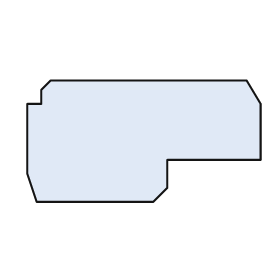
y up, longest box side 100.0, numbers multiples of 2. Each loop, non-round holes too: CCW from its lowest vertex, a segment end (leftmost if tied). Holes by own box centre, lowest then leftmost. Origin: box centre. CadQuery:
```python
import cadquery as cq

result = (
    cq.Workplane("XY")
    .moveTo(-46.0, -26.0)
    .lineTo(4.0, -26.0)
    .lineTo(10.0, -20.0)
    .lineTo(10.0, -8.0)
    .lineTo(50.0, -8.0)
    .lineTo(50.0, 16.0)
    .lineTo(44.0, 26.0)
    .lineTo(-40.0, 26.0)
    .lineTo(-44.0, 22.0)
    .lineTo(-44.0, 16.0)
    .lineTo(-50.0, 16.0)
    .lineTo(-50.0, -14.0)
    .close()
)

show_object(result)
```